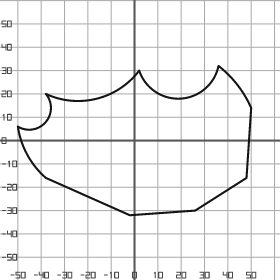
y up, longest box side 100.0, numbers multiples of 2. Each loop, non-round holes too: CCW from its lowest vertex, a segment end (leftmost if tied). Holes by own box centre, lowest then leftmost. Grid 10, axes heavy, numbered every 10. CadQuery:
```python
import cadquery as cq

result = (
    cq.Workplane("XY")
    .moveTo(-2.0, -32.0)
    .lineTo(26.0, -30.0)
    .lineTo(48.0, -16.0)
    .lineTo(50.0, 14.0)
    .threePointArc((44.0, 24.0), (36.0, 32.0))
    .threePointArc((20.0, 18.0), (2.0, 30.0))
    .threePointArc((-16.0, 18.0), (-38.0, 20.0))
    .threePointArc((-38.0, 8.0), (-50.0, 6.0))
    .threePointArc((-46.0, -6.0), (-38.0, -16.0))
    .close()
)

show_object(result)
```